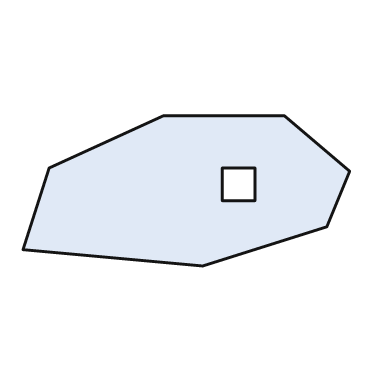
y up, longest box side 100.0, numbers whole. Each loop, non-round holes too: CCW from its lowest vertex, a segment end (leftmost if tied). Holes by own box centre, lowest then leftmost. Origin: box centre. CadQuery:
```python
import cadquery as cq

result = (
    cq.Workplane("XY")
    .moveTo(5.0, -23.0)
    .lineTo(43.0, -11.0)
    .lineTo(50.0, 6.0)
    .lineTo(30.0, 23.0)
    .lineTo(-7.0, 23.0)
    .lineTo(-42.0, 7.0)
    .lineTo(-50.0, -18.0)
    .close()
    .moveTo(11.0, -3.0)
    .lineTo(21.0, -3.0)
    .lineTo(21.0, 7.0)
    .lineTo(11.0, 7.0)
    .close()
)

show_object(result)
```